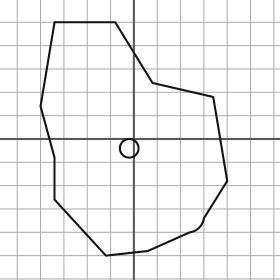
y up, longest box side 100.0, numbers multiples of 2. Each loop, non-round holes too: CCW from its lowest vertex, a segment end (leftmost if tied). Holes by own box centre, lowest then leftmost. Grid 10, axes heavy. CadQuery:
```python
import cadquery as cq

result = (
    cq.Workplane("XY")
    .moveTo(-12.0, -50.0)
    .lineTo(6.0, -48.0)
    .lineTo(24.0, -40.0)
    .threePointArc((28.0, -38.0), (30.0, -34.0))
    .lineTo(40.0, -18.0)
    .lineTo(34.0, 18.0)
    .lineTo(8.0, 24.0)
    .lineTo(-8.0, 50.0)
    .lineTo(-34.0, 50.0)
    .lineTo(-40.0, 14.0)
    .lineTo(-34.0, -8.0)
    .lineTo(-34.0, -26.0)
    .close()
    .moveTo(-2.0, -4.0)
    .circle(4.0)
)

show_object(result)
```